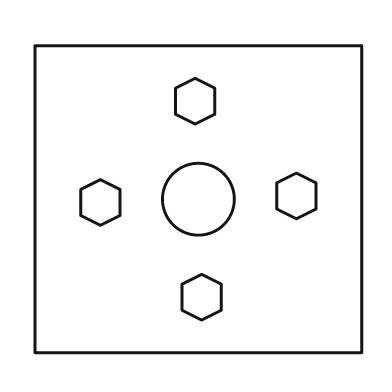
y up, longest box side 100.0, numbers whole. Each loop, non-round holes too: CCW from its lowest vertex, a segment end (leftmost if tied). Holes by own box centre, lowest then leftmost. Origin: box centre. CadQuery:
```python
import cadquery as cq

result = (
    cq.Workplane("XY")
    .moveTo(-50.0, -47.0)
    .lineTo(50.0, -47.0)
    .lineTo(50.0, 47.0)
    .lineTo(-50.0, 47.0)
    .close()
    .moveTo(1.0, -37.0)
    .lineTo(7.0, -34.0)
    .lineTo(7.0, -26.0)
    .lineTo(1.0, -23.0)
    .lineTo(-5.0, -26.0)
    .lineTo(-5.0, -34.0)
    .close()
    .moveTo(-30.0, -8.0)
    .lineTo(-24.0, -5.0)
    .lineTo(-24.0, 3.0)
    .lineTo(-30.0, 6.0)
    .lineTo(-36.0, 3.0)
    .lineTo(-36.0, -5.0)
    .close()
    .moveTo(0.0, 0.0)
    .circle(11.0)
    .moveTo(30.0, -6.0)
    .lineTo(36.0, -3.0)
    .lineTo(36.0, 5.0)
    .lineTo(30.0, 8.0)
    .lineTo(24.0, 5.0)
    .lineTo(24.0, -3.0)
    .close()
    .moveTo(-1.0, 23.0)
    .lineTo(5.0, 26.0)
    .lineTo(5.0, 34.0)
    .lineTo(-1.0, 37.0)
    .lineTo(-7.0, 34.0)
    .lineTo(-7.0, 26.0)
    .close()
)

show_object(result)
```